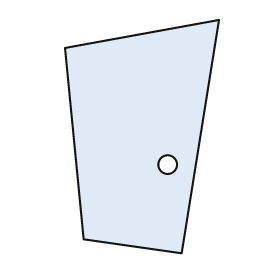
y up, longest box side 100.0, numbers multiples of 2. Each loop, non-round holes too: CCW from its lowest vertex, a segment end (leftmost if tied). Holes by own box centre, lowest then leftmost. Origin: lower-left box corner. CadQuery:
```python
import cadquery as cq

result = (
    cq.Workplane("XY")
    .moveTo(50.0, 0.0)
    .lineTo(66.0, 100.0)
    .lineTo(0.0, 88.0)
    .lineTo(8.0, 6.0)
    .close()
    .moveTo(44.0, 38.0)
    .circle(4.0)
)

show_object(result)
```